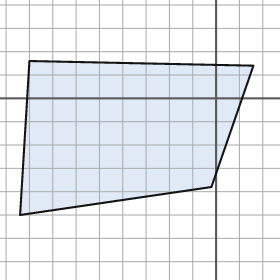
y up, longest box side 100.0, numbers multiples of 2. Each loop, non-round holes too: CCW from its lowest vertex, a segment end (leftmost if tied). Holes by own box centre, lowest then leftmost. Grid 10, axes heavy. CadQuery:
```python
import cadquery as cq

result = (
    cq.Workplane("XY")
    .moveTo(-84.0, -50.0)
    .lineTo(-2.0, -38.0)
    .lineTo(16.0, 14.0)
    .lineTo(-80.0, 16.0)
    .close()
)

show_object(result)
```